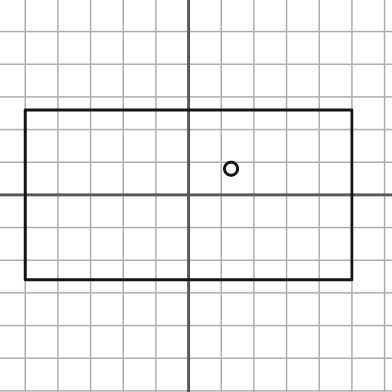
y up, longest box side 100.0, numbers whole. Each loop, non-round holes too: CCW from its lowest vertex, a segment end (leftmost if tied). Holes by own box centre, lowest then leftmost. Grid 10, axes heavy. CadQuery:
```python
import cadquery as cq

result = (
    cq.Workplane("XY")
    .moveTo(-50.0, -26.0)
    .lineTo(50.0, -26.0)
    .lineTo(50.0, 26.0)
    .lineTo(-50.0, 26.0)
    .close()
    .moveTo(13.0, 8.0)
    .circle(2.0)
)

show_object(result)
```